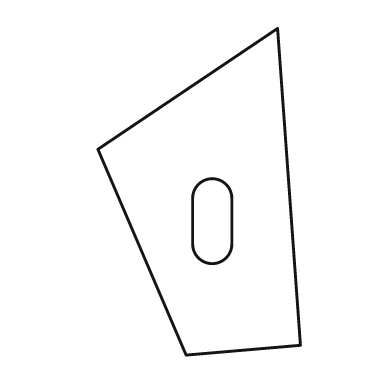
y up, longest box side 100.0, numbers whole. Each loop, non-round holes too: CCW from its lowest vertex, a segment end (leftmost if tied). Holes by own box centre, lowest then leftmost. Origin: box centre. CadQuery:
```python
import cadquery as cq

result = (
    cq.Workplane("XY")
    .moveTo(-4.0, -50.0)
    .lineTo(31.0, -47.0)
    .lineTo(24.0, 50.0)
    .lineTo(-31.0, 13.0)
    .close()
    .moveTo(-2.0, -16.0)
    .threePointArc((4.0, -22.0), (10.0, -16.0))
    .lineTo(10.0, -2.0)
    .threePointArc((4.0, 4.0), (-2.0, -2.0))
    .close()
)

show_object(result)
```